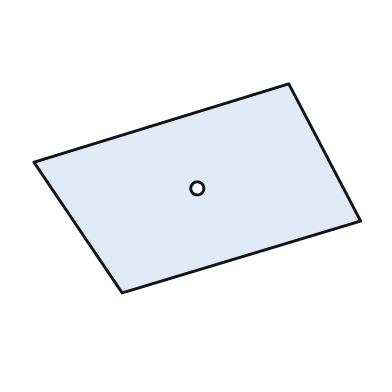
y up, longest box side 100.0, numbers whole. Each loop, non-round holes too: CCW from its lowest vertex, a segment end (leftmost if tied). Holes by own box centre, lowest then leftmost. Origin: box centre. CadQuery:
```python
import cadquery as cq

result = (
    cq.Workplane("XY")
    .moveTo(-23.0, -32.0)
    .lineTo(50.0, -10.0)
    .lineTo(28.0, 32.0)
    .lineTo(-50.0, 8.0)
    .close()
    .moveTo(0.0, 0.0)
    .circle(2.0)
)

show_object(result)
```